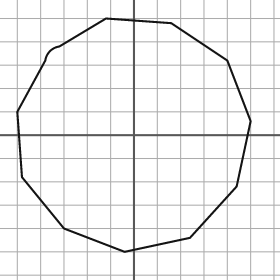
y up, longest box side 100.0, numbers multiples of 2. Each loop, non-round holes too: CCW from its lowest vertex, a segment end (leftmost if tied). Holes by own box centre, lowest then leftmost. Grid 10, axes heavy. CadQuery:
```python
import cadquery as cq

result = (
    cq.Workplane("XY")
    .moveTo(-4.0, -50.0)
    .lineTo(24.0, -44.0)
    .lineTo(44.0, -22.0)
    .lineTo(50.0, 6.0)
    .lineTo(40.0, 32.0)
    .lineTo(16.0, 48.0)
    .lineTo(-12.0, 50.0)
    .lineTo(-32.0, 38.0)
    .threePointArc((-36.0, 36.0), (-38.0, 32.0))
    .lineTo(-50.0, 10.0)
    .lineTo(-48.0, -18.0)
    .lineTo(-30.0, -40.0)
    .close()
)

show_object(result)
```